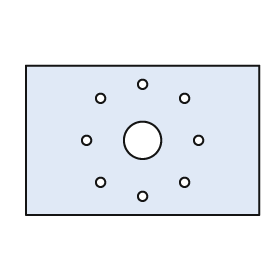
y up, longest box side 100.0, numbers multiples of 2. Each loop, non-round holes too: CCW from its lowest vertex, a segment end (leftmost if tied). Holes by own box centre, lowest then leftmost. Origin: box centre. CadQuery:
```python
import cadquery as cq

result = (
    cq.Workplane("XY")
    .moveTo(-50.0, -32.0)
    .lineTo(50.0, -32.0)
    .lineTo(50.0, 32.0)
    .lineTo(-50.0, 32.0)
    .close()
    .moveTo(0.0, -24.0)
    .circle(2.0)
    .moveTo(-18.0, -18.0)
    .circle(2.0)
    .moveTo(18.0, -18.0)
    .circle(2.0)
    .moveTo(-24.0, 0.0)
    .circle(2.0)
    .moveTo(0.0, 0.0)
    .circle(8.0)
    .moveTo(24.0, 0.0)
    .circle(2.0)
    .moveTo(-18.0, 18.0)
    .circle(2.0)
    .moveTo(18.0, 18.0)
    .circle(2.0)
    .moveTo(0.0, 24.0)
    .circle(2.0)
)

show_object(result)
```